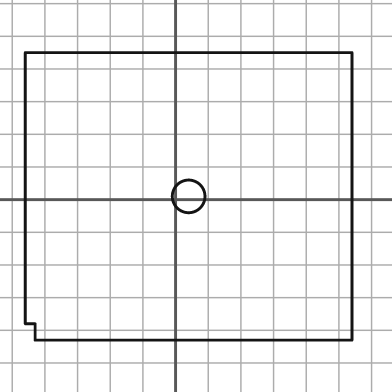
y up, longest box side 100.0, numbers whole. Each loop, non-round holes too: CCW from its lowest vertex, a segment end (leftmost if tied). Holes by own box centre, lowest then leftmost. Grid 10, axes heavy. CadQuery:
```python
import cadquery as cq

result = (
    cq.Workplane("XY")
    .moveTo(-43.0, -43.0)
    .lineTo(54.0, -43.0)
    .lineTo(54.0, 45.0)
    .lineTo(-46.0, 45.0)
    .lineTo(-46.0, -38.0)
    .lineTo(-43.0, -38.0)
    .close()
    .moveTo(4.0, 1.0)
    .circle(5.0)
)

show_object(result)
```